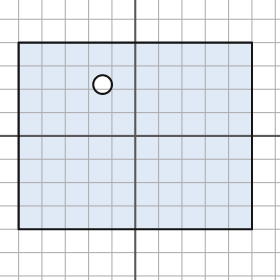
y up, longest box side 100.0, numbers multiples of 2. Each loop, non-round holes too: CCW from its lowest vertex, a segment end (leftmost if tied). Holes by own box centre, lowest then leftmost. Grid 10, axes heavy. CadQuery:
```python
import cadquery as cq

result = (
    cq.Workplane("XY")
    .moveTo(-50.0, -40.0)
    .lineTo(50.0, -40.0)
    .lineTo(50.0, 40.0)
    .lineTo(-50.0, 40.0)
    .close()
    .moveTo(-14.0, 22.0)
    .circle(4.0)
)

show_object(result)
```